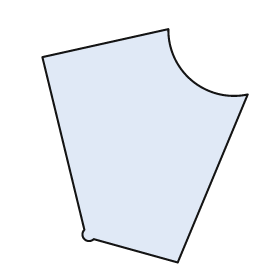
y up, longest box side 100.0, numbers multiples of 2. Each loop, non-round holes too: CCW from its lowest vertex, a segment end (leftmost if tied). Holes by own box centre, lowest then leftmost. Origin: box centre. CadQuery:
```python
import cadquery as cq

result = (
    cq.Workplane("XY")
    .moveTo(14.0, -50.0)
    .lineTo(44.0, 22.0)
    .threePointArc((20.0, 28.0), (10.0, 50.0))
    .lineTo(-44.0, 38.0)
    .lineTo(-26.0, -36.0)
    .threePointArc((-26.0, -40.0), (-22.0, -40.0))
    .close()
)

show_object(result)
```